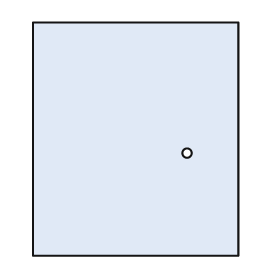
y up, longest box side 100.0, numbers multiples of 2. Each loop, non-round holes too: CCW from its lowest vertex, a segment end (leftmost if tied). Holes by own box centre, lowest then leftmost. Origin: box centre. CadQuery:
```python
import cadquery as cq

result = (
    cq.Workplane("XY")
    .moveTo(-44.0, -50.0)
    .lineTo(44.0, -50.0)
    .lineTo(44.0, 50.0)
    .lineTo(-44.0, 50.0)
    .close()
    .moveTo(22.0, -6.0)
    .circle(2.0)
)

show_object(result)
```